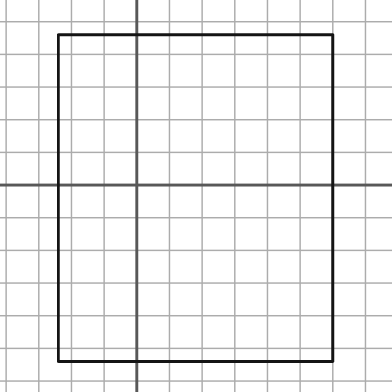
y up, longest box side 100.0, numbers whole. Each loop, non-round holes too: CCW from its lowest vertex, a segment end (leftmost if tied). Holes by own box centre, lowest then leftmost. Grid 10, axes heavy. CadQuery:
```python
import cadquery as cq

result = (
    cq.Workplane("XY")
    .moveTo(-24.0, -54.0)
    .lineTo(60.0, -54.0)
    .lineTo(60.0, 46.0)
    .lineTo(-24.0, 46.0)
    .close()
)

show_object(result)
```